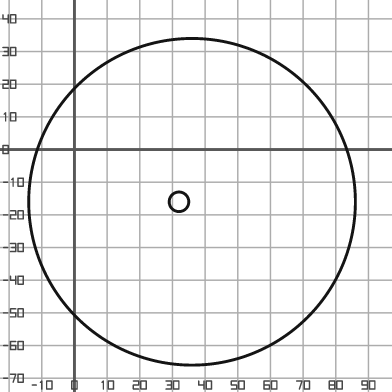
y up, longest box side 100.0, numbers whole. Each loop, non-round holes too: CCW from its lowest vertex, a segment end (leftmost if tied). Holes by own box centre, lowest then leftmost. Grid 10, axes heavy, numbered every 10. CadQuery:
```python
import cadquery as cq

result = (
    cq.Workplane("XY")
    .moveTo(36.0, -16.0)
    .circle(50.0)
    .moveTo(32.0, -16.0)
    .circle(3.0)
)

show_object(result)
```